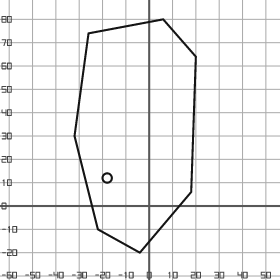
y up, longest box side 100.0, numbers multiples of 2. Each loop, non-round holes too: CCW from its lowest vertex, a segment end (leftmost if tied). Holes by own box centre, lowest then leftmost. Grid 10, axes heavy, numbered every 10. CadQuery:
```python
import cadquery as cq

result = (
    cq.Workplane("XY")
    .moveTo(-4.0, -20.0)
    .lineTo(18.0, 6.0)
    .lineTo(20.0, 64.0)
    .lineTo(6.0, 80.0)
    .lineTo(-26.0, 74.0)
    .lineTo(-32.0, 30.0)
    .lineTo(-22.0, -10.0)
    .close()
    .moveTo(-18.0, 12.0)
    .circle(2.0)
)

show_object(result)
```